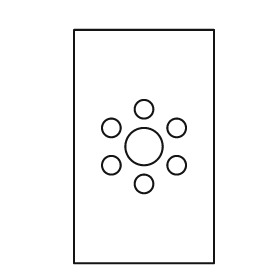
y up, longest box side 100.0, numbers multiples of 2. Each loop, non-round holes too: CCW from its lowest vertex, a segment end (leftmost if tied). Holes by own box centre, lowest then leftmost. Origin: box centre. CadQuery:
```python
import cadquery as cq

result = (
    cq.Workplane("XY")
    .moveTo(-30.0, -50.0)
    .lineTo(30.0, -50.0)
    .lineTo(30.0, 50.0)
    .lineTo(-30.0, 50.0)
    .close()
    .moveTo(0.0, -16.0)
    .circle(4.0)
    .moveTo(-14.0, -8.0)
    .circle(4.0)
    .moveTo(14.0, -8.0)
    .circle(4.0)
    .moveTo(0.0, 0.0)
    .circle(8.0)
    .moveTo(-14.0, 8.0)
    .circle(4.0)
    .moveTo(14.0, 8.0)
    .circle(4.0)
    .moveTo(0.0, 16.0)
    .circle(4.0)
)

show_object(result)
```